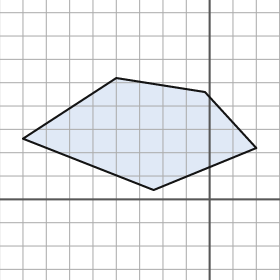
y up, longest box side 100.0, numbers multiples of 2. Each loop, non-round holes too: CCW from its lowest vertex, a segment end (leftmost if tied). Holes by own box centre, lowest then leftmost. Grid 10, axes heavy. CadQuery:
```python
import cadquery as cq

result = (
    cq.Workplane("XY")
    .moveTo(-24.0, 4.0)
    .lineTo(20.0, 22.0)
    .lineTo(-2.0, 46.0)
    .lineTo(-40.0, 52.0)
    .lineTo(-80.0, 26.0)
    .close()
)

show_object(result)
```